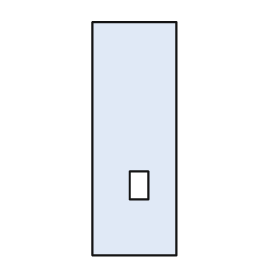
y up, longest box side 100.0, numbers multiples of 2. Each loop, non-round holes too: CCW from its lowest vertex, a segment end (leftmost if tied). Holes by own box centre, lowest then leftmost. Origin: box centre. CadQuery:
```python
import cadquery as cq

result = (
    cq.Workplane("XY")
    .moveTo(-18.0, -50.0)
    .lineTo(18.0, -50.0)
    .lineTo(18.0, 50.0)
    .lineTo(-18.0, 50.0)
    .close()
    .moveTo(-2.0, -26.0)
    .lineTo(6.0, -26.0)
    .lineTo(6.0, -14.0)
    .lineTo(-2.0, -14.0)
    .close()
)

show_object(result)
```